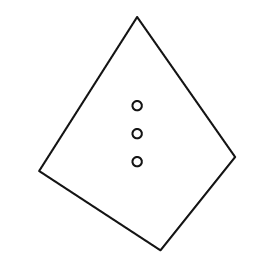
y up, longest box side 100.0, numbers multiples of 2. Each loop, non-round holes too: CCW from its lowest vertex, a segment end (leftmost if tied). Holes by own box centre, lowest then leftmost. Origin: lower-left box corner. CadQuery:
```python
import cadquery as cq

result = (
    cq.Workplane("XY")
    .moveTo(52.0, 0.0)
    .lineTo(84.0, 40.0)
    .lineTo(42.0, 100.0)
    .lineTo(0.0, 34.0)
    .close()
    .moveTo(42.0, 38.0)
    .circle(2.0)
    .moveTo(42.0, 50.0)
    .circle(2.0)
    .moveTo(42.0, 62.0)
    .circle(2.0)
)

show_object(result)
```